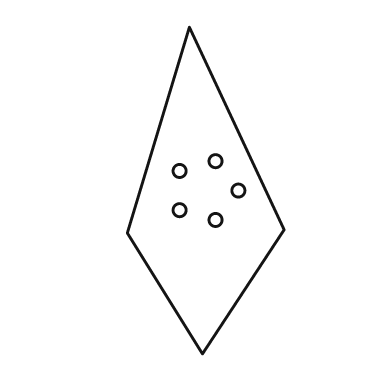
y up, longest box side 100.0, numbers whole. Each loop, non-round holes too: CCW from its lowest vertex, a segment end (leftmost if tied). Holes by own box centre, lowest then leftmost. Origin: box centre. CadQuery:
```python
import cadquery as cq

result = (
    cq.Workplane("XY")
    .moveTo(-1.0, -50.0)
    .lineTo(24.0, -12.0)
    .lineTo(-5.0, 50.0)
    .lineTo(-24.0, -13.0)
    .close()
    .moveTo(3.0, -9.0)
    .circle(2.0)
    .moveTo(-8.0, -6.0)
    .circle(2.0)
    .moveTo(10.0, 0.0)
    .circle(2.0)
    .moveTo(-8.0, 6.0)
    .circle(2.0)
    .moveTo(3.0, 9.0)
    .circle(2.0)
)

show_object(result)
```